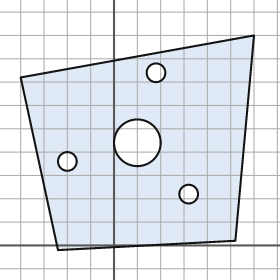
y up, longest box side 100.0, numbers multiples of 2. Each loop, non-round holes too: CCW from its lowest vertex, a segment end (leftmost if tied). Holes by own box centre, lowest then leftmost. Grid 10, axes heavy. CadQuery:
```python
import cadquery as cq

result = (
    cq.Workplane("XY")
    .moveTo(-24.0, -2.0)
    .lineTo(52.0, 2.0)
    .lineTo(60.0, 90.0)
    .lineTo(-40.0, 72.0)
    .close()
    .moveTo(32.0, 22.0)
    .circle(4.0)
    .moveTo(-20.0, 36.0)
    .circle(4.0)
    .moveTo(10.0, 44.0)
    .circle(10.0)
    .moveTo(18.0, 74.0)
    .circle(4.0)
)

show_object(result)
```